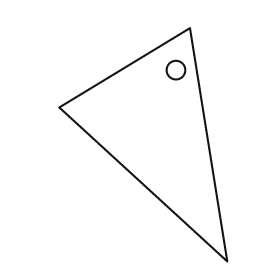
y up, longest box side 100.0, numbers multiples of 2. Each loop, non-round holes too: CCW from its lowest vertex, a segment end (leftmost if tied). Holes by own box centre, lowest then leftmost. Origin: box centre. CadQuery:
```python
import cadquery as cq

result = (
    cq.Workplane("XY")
    .moveTo(36.0, -50.0)
    .lineTo(20.0, 50.0)
    .lineTo(-36.0, 16.0)
    .close()
    .moveTo(14.0, 32.0)
    .circle(4.0)
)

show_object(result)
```